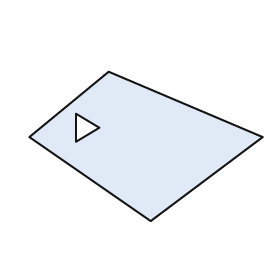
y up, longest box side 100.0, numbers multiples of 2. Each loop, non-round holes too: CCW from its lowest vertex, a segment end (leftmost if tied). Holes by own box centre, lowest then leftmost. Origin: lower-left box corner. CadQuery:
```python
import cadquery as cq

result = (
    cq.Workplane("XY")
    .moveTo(52.0, 0.0)
    .lineTo(100.0, 36.0)
    .lineTo(34.0, 64.0)
    .lineTo(0.0, 36.0)
    .close()
    .moveTo(20.0, 34.0)
    .lineTo(30.0, 40.0)
    .lineTo(20.0, 46.0)
    .close()
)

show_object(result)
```